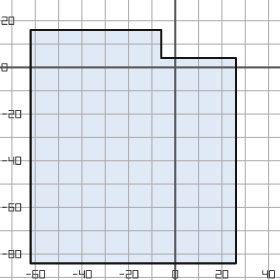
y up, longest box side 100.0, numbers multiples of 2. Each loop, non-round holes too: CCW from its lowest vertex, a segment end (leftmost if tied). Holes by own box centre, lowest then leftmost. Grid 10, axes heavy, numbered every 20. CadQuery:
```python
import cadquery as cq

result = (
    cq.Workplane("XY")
    .moveTo(-62.0, -84.0)
    .lineTo(26.0, -84.0)
    .lineTo(26.0, 4.0)
    .lineTo(-6.0, 4.0)
    .lineTo(-6.0, 16.0)
    .lineTo(-62.0, 16.0)
    .close()
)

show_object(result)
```